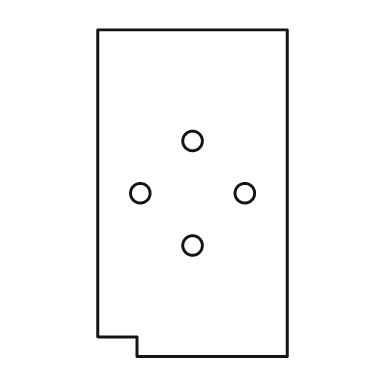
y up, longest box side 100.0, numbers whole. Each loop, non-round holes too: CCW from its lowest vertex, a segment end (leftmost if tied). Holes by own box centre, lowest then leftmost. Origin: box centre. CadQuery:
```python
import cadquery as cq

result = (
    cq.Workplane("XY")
    .moveTo(-17.0, -50.0)
    .lineTo(29.0, -50.0)
    .lineTo(29.0, 50.0)
    .lineTo(-29.0, 50.0)
    .lineTo(-29.0, -44.0)
    .lineTo(-17.0, -44.0)
    .close()
    .moveTo(0.0, -16.0)
    .circle(3.0)
    .moveTo(-16.0, 0.0)
    .circle(3.0)
    .moveTo(16.0, 0.0)
    .circle(3.0)
    .moveTo(0.0, 16.0)
    .circle(3.0)
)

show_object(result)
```